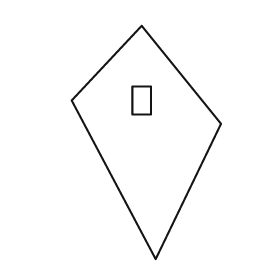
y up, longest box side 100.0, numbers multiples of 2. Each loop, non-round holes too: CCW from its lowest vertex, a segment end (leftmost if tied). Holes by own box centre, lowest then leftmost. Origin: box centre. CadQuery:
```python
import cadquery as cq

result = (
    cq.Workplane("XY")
    .moveTo(4.0, -50.0)
    .lineTo(32.0, 8.0)
    .lineTo(-2.0, 50.0)
    .lineTo(-32.0, 18.0)
    .close()
    .moveTo(-6.0, 12.0)
    .lineTo(2.0, 12.0)
    .lineTo(2.0, 24.0)
    .lineTo(-6.0, 24.0)
    .close()
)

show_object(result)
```